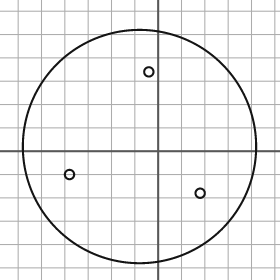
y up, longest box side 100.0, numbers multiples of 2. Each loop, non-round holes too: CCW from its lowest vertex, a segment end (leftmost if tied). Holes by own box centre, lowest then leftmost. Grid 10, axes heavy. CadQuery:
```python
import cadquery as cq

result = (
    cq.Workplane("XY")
    .moveTo(-8.0, 2.0)
    .circle(50.0)
    .moveTo(18.0, -18.0)
    .circle(2.0)
    .moveTo(-38.0, -10.0)
    .circle(2.0)
    .moveTo(-4.0, 34.0)
    .circle(2.0)
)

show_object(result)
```